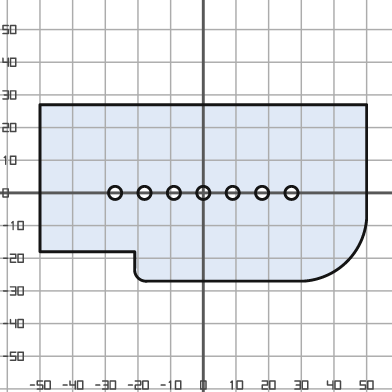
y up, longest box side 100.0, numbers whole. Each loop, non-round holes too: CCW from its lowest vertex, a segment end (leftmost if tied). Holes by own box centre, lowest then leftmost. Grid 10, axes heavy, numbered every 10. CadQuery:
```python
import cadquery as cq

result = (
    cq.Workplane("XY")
    .moveTo(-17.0, -27.0)
    .lineTo(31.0, -27.0)
    .threePointArc((44.0, -21.0), (50.0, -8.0))
    .lineTo(50.0, 27.0)
    .lineTo(-50.0, 27.0)
    .lineTo(-50.0, -18.0)
    .lineTo(-21.0, -18.0)
    .lineTo(-21.0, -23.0)
    .threePointArc((-20.0, -26.0), (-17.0, -27.0))
    .close()
    .moveTo(-27.0, 0.0)
    .circle(2.0)
    .moveTo(-18.0, 0.0)
    .circle(2.0)
    .moveTo(-9.0, 0.0)
    .circle(2.0)
    .moveTo(0.0, 0.0)
    .circle(2.0)
    .moveTo(9.0, 0.0)
    .circle(2.0)
    .moveTo(18.0, 0.0)
    .circle(2.0)
    .moveTo(27.0, 0.0)
    .circle(2.0)
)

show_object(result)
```